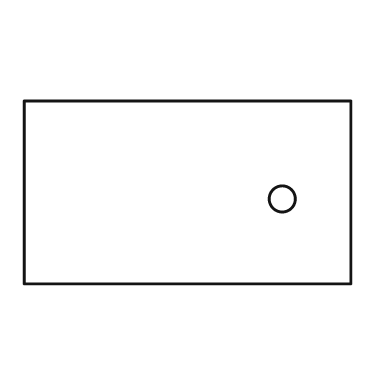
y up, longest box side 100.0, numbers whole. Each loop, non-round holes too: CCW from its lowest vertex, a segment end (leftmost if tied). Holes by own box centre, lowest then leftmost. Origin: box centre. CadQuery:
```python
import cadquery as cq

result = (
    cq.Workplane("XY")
    .moveTo(-50.0, -28.0)
    .lineTo(50.0, -28.0)
    .lineTo(50.0, 28.0)
    .lineTo(-50.0, 28.0)
    .close()
    .moveTo(29.0, -2.0)
    .circle(4.0)
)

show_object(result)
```